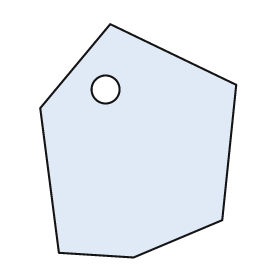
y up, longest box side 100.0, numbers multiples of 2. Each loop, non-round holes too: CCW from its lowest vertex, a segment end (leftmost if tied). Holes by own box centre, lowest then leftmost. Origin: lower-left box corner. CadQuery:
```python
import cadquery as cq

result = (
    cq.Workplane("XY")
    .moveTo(40.0, 0.0)
    .lineTo(78.0, 16.0)
    .lineTo(84.0, 74.0)
    .lineTo(30.0, 100.0)
    .lineTo(0.0, 64.0)
    .lineTo(8.0, 2.0)
    .close()
    .moveTo(28.0, 72.0)
    .circle(6.0)
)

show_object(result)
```